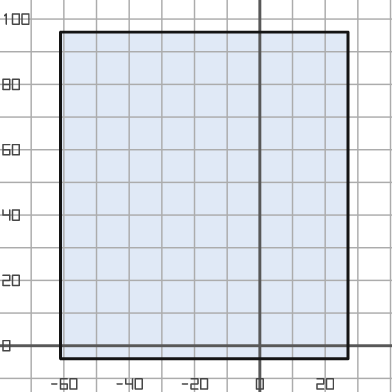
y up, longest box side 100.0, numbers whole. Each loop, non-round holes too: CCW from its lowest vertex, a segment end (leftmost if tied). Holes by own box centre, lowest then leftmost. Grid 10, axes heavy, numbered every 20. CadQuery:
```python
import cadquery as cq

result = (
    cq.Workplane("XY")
    .moveTo(-61.0, -4.0)
    .lineTo(27.0, -4.0)
    .lineTo(27.0, 96.0)
    .lineTo(-61.0, 96.0)
    .close()
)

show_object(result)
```